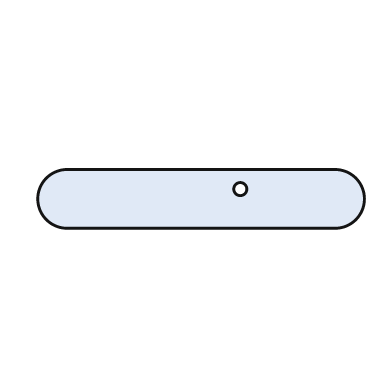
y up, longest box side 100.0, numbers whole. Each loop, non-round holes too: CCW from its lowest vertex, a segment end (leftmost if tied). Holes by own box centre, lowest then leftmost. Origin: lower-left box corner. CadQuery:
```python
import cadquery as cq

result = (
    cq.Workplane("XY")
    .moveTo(9.0, 0.0)
    .lineTo(91.0, 0.0)
    .threePointArc((100.0, 9.0), (91.0, 18.0))
    .lineTo(9.0, 18.0)
    .threePointArc((0.0, 9.0), (9.0, 0.0))
    .close()
    .moveTo(62.0, 12.0)
    .circle(2.0)
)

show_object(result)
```